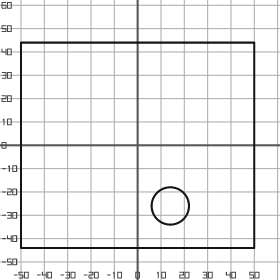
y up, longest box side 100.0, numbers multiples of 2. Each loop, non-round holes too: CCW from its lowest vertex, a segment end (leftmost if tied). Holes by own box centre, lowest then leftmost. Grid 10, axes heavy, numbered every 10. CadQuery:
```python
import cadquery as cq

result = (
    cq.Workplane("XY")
    .moveTo(-50.0, -44.0)
    .lineTo(50.0, -44.0)
    .lineTo(50.0, 44.0)
    .lineTo(-50.0, 44.0)
    .close()
    .moveTo(14.0, -26.0)
    .circle(8.0)
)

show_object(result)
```